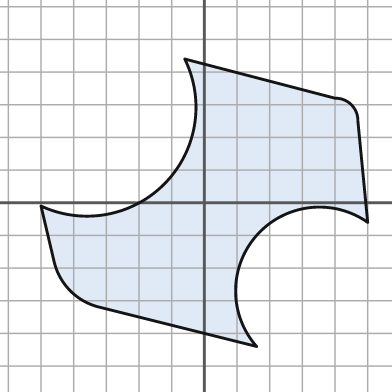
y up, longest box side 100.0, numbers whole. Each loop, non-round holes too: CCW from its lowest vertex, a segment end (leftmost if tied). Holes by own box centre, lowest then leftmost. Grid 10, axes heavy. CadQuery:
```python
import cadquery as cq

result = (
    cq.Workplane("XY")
    .moveTo(16.0, -44.0)
    .threePointArc((16.0, -10.0), (50.0, -6.0))
    .lineTo(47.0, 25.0)
    .threePointArc((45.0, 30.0), (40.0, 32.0))
    .lineTo(-6.0, 44.0)
    .threePointArc((-12.0, 6.0), (-50.0, -1.0))
    .lineTo(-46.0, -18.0)
    .threePointArc((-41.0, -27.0), (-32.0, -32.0))
    .close()
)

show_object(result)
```